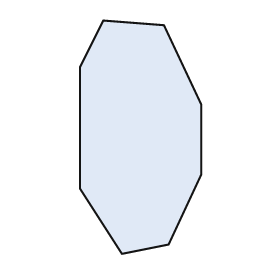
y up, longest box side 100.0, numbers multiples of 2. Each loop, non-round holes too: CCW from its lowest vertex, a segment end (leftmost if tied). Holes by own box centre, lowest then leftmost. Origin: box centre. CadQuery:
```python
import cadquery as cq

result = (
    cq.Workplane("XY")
    .moveTo(-8.0, -50.0)
    .lineTo(12.0, -46.0)
    .lineTo(26.0, -16.0)
    .lineTo(26.0, 14.0)
    .lineTo(10.0, 48.0)
    .lineTo(-16.0, 50.0)
    .lineTo(-26.0, 30.0)
    .lineTo(-26.0, -22.0)
    .close()
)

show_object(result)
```